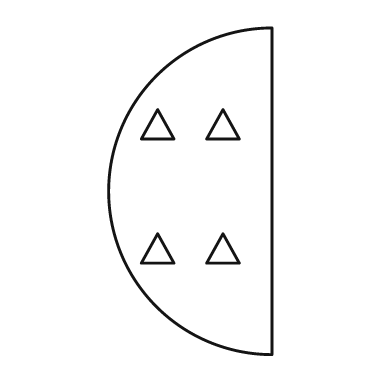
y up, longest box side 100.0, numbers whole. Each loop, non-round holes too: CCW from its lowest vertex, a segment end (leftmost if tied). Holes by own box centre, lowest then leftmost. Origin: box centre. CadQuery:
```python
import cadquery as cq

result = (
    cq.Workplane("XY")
    .moveTo(25.0, -50.0)
    .lineTo(25.0, 50.0)
    .threePointArc((-25.0, 0.0), (25.0, -50.0))
    .close()
    .moveTo(-15.0, -22.0)
    .lineTo(-5.0, -22.0)
    .lineTo(-10.0, -13.0)
    .close()
    .moveTo(5.0, -22.0)
    .lineTo(15.0, -22.0)
    .lineTo(10.0, -13.0)
    .close()
    .moveTo(-15.0, 16.0)
    .lineTo(-5.0, 16.0)
    .lineTo(-10.0, 25.0)
    .close()
    .moveTo(5.0, 16.0)
    .lineTo(15.0, 16.0)
    .lineTo(10.0, 25.0)
    .close()
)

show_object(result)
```